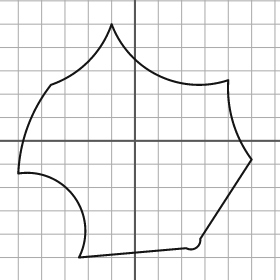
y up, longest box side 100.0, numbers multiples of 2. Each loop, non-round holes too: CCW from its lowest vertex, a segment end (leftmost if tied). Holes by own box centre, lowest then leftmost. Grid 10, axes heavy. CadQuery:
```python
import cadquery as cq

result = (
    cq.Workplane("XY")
    .moveTo(-24.0, -50.0)
    .lineTo(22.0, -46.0)
    .threePointArc((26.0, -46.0), (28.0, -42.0))
    .lineTo(50.0, -8.0)
    .threePointArc((42.0, 8.0), (40.0, 26.0))
    .threePointArc((10.0, 28.0), (-10.0, 50.0))
    .threePointArc((-20.0, 34.0), (-36.0, 24.0))
    .threePointArc((-46.0, 6.0), (-50.0, -14.0))
    .threePointArc((-26.0, -24.0), (-24.0, -50.0))
    .close()
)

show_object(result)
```